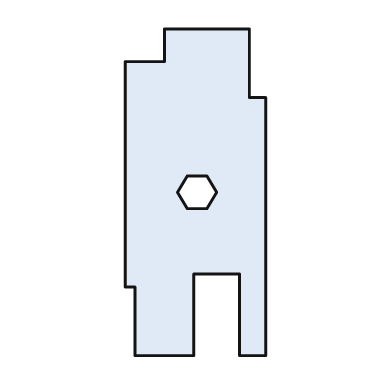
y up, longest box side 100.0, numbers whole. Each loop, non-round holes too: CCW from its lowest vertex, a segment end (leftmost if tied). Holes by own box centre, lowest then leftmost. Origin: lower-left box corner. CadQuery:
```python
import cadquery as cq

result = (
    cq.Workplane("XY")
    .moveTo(3.0, 0.0)
    .lineTo(21.0, 0.0)
    .lineTo(21.0, 25.0)
    .lineTo(35.0, 25.0)
    .lineTo(35.0, 0.0)
    .lineTo(43.0, 0.0)
    .lineTo(43.0, 79.0)
    .lineTo(38.0, 79.0)
    .lineTo(38.0, 100.0)
    .lineTo(12.0, 100.0)
    .lineTo(12.0, 90.0)
    .lineTo(0.0, 90.0)
    .lineTo(0.0, 21.0)
    .lineTo(3.0, 21.0)
    .close()
    .moveTo(19.0, 45.0)
    .lineTo(25.0, 45.0)
    .lineTo(28.0, 50.0)
    .lineTo(25.0, 55.0)
    .lineTo(19.0, 55.0)
    .lineTo(16.0, 50.0)
    .close()
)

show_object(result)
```